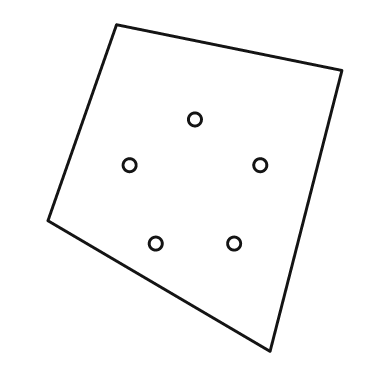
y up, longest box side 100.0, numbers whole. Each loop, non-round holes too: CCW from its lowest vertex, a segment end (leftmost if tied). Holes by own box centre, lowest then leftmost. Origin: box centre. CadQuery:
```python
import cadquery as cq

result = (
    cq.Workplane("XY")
    .moveTo(23.0, -50.0)
    .lineTo(45.0, 36.0)
    .lineTo(-24.0, 50.0)
    .lineTo(-45.0, -10.0)
    .close()
    .moveTo(-12.0, -17.0)
    .circle(2.0)
    .moveTo(12.0, -17.0)
    .circle(2.0)
    .moveTo(-20.0, 7.0)
    .circle(2.0)
    .moveTo(20.0, 7.0)
    .circle(2.0)
    .moveTo(0.0, 21.0)
    .circle(2.0)
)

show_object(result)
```